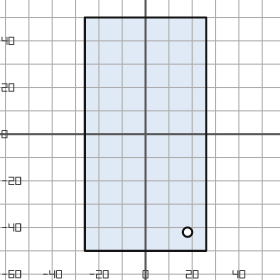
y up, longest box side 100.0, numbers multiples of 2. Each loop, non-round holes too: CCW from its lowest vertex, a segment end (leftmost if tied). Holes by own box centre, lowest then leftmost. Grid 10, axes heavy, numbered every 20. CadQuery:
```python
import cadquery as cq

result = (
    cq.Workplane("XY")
    .moveTo(-26.0, -50.0)
    .lineTo(26.0, -50.0)
    .lineTo(26.0, 50.0)
    .lineTo(-26.0, 50.0)
    .close()
    .moveTo(18.0, -42.0)
    .circle(2.0)
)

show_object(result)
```